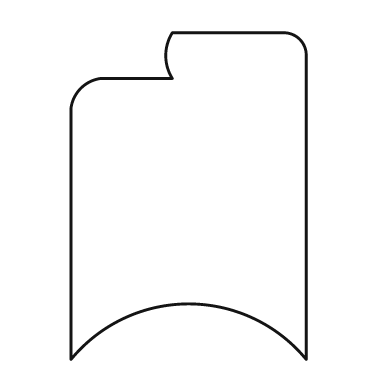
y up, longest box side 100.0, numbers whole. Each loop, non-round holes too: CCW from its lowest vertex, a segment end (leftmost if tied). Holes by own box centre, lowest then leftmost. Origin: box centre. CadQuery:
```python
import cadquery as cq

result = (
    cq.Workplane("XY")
    .moveTo(-36.0, -50.0)
    .threePointArc((0.0, -33.0), (36.0, -50.0))
    .lineTo(36.0, 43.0)
    .threePointArc((34.0, 48.0), (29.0, 50.0))
    .lineTo(-5.0, 50.0)
    .threePointArc((-7.0, 43.0), (-5.0, 36.0))
    .lineTo(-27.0, 36.0)
    .threePointArc((-33.0, 33.0), (-36.0, 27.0))
    .close()
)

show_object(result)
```